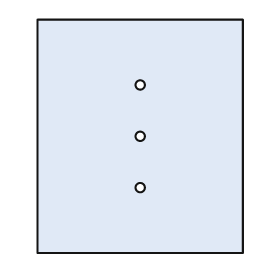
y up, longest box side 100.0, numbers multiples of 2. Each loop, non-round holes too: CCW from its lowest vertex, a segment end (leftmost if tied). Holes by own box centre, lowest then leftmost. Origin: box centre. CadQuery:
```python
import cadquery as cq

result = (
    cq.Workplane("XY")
    .moveTo(-44.0, -50.0)
    .lineTo(44.0, -50.0)
    .lineTo(44.0, 50.0)
    .lineTo(-44.0, 50.0)
    .close()
    .moveTo(0.0, -22.0)
    .circle(2.0)
    .moveTo(0.0, 0.0)
    .circle(2.0)
    .moveTo(0.0, 22.0)
    .circle(2.0)
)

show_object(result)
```